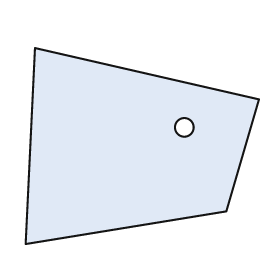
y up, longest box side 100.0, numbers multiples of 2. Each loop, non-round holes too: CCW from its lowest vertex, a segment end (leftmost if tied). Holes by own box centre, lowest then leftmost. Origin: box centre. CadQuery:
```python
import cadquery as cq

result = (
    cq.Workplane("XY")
    .moveTo(-50.0, -42.0)
    .lineTo(36.0, -28.0)
    .lineTo(50.0, 20.0)
    .lineTo(-46.0, 42.0)
    .close()
    .moveTo(18.0, 8.0)
    .circle(4.0)
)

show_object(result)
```